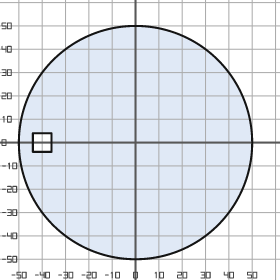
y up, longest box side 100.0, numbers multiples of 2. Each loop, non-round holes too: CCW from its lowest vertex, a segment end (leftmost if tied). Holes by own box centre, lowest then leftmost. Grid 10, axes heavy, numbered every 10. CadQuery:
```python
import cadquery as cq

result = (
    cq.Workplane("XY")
    .moveTo(0.0, 0.0)
    .circle(50.0)
    .moveTo(-44.0, -4.0)
    .lineTo(-36.0, -4.0)
    .lineTo(-36.0, 4.0)
    .lineTo(-44.0, 4.0)
    .close()
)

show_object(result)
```